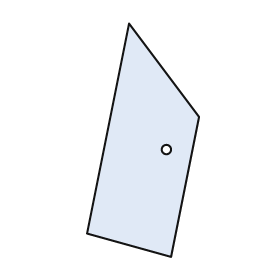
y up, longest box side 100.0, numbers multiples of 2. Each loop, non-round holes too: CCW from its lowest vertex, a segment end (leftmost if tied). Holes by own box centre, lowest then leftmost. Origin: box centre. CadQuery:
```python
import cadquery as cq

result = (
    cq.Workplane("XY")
    .moveTo(12.0, -50.0)
    .lineTo(24.0, 10.0)
    .lineTo(-6.0, 50.0)
    .lineTo(-24.0, -40.0)
    .close()
    .moveTo(10.0, -4.0)
    .circle(2.0)
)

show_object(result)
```